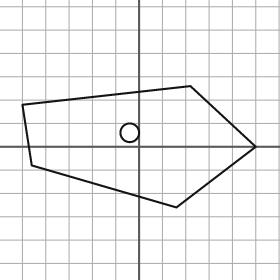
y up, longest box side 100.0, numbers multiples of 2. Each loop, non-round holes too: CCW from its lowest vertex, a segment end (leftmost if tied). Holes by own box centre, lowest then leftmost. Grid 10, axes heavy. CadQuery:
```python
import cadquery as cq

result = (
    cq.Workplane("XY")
    .moveTo(16.0, -26.0)
    .lineTo(50.0, 0.0)
    .lineTo(22.0, 26.0)
    .lineTo(-50.0, 18.0)
    .lineTo(-46.0, -8.0)
    .close()
    .moveTo(-4.0, 6.0)
    .circle(4.0)
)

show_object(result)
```